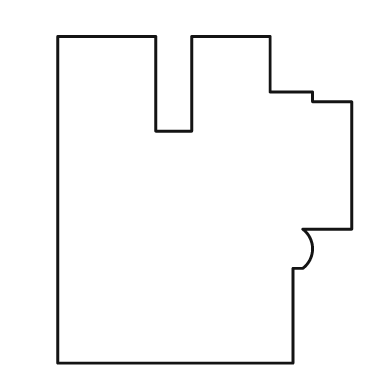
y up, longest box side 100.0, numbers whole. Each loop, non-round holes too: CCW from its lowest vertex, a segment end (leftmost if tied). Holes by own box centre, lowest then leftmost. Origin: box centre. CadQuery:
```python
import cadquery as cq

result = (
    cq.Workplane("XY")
    .moveTo(-45.0, -50.0)
    .lineTo(27.0, -50.0)
    .lineTo(27.0, -21.0)
    .lineTo(30.0, -21.0)
    .threePointArc((33.0, -15.0), (30.0, -9.0))
    .lineTo(45.0, -9.0)
    .lineTo(45.0, 30.0)
    .lineTo(33.0, 30.0)
    .lineTo(33.0, 33.0)
    .lineTo(20.0, 33.0)
    .lineTo(20.0, 50.0)
    .lineTo(-4.0, 50.0)
    .lineTo(-4.0, 21.0)
    .lineTo(-15.0, 21.0)
    .lineTo(-15.0, 50.0)
    .lineTo(-45.0, 50.0)
    .close()
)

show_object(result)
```